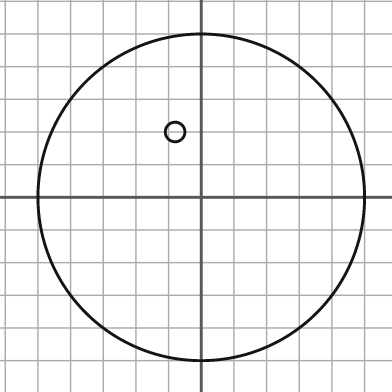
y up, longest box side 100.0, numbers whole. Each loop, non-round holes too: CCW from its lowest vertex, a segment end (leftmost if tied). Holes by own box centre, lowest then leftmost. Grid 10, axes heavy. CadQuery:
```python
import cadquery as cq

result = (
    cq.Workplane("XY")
    .moveTo(0.0, 0.0)
    .circle(50.0)
    .moveTo(-8.0, 20.0)
    .circle(3.0)
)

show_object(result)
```